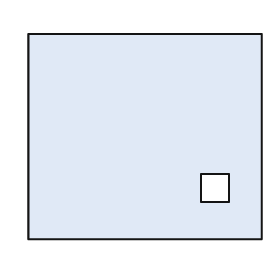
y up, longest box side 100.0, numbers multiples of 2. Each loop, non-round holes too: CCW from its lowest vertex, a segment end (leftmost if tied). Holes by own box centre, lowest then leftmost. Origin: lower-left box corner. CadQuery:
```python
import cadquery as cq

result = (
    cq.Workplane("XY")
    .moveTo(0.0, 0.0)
    .lineTo(100.0, 0.0)
    .lineTo(100.0, 88.0)
    .lineTo(0.0, 88.0)
    .close()
    .moveTo(74.0, 16.0)
    .lineTo(86.0, 16.0)
    .lineTo(86.0, 28.0)
    .lineTo(74.0, 28.0)
    .close()
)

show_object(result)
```